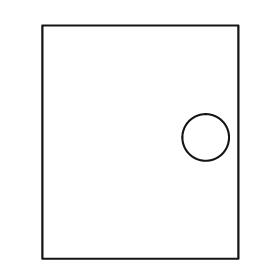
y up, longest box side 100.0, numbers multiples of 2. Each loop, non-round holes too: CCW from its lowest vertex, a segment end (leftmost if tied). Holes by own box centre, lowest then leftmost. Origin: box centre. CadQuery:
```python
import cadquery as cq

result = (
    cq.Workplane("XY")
    .moveTo(-42.0, -50.0)
    .lineTo(42.0, -50.0)
    .lineTo(42.0, 50.0)
    .lineTo(-42.0, 50.0)
    .close()
    .moveTo(28.0, 2.0)
    .circle(10.0)
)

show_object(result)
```